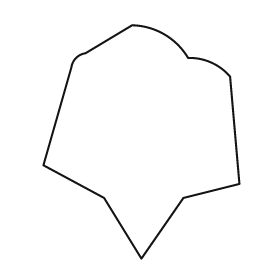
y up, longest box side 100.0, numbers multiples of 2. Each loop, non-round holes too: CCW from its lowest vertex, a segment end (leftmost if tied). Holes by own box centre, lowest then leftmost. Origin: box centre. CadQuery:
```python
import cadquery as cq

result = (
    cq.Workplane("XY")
    .moveTo(0.0, -50.0)
    .lineTo(18.0, -24.0)
    .lineTo(42.0, -18.0)
    .lineTo(38.0, 28.0)
    .threePointArc((30.0, 34.0), (20.0, 36.0))
    .threePointArc((10.0, 46.0), (-4.0, 50.0))
    .lineTo(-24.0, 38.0)
    .threePointArc((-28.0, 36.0), (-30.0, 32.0))
    .lineTo(-42.0, -10.0)
    .lineTo(-16.0, -24.0)
    .close()
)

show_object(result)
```